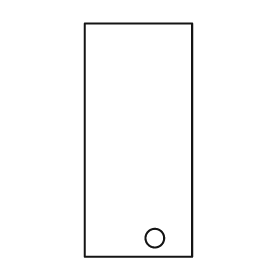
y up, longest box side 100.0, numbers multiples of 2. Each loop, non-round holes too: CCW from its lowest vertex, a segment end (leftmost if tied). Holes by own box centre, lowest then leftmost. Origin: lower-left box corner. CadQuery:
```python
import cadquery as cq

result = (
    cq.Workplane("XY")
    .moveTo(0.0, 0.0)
    .lineTo(46.0, 0.0)
    .lineTo(46.0, 100.0)
    .lineTo(0.0, 100.0)
    .close()
    .moveTo(30.0, 8.0)
    .circle(4.0)
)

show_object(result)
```